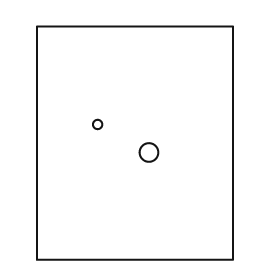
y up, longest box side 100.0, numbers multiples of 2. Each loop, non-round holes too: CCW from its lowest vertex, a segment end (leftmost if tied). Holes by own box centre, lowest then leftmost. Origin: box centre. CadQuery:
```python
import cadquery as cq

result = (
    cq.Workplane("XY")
    .moveTo(-42.0, -50.0)
    .lineTo(42.0, -50.0)
    .lineTo(42.0, 50.0)
    .lineTo(-42.0, 50.0)
    .close()
    .moveTo(6.0, -4.0)
    .circle(4.0)
    .moveTo(-16.0, 8.0)
    .circle(2.0)
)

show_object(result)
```